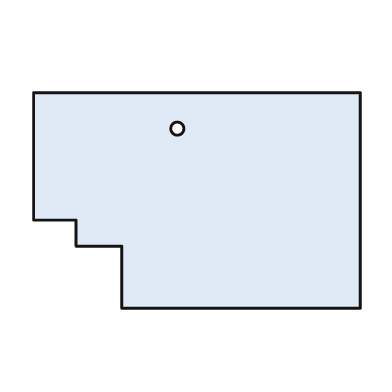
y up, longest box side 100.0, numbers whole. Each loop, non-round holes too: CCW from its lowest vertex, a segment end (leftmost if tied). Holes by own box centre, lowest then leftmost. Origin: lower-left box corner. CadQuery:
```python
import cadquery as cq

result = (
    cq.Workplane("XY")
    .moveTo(27.0, 0.0)
    .lineTo(100.0, 0.0)
    .lineTo(100.0, 66.0)
    .lineTo(0.0, 66.0)
    .lineTo(0.0, 27.0)
    .lineTo(13.0, 27.0)
    .lineTo(13.0, 19.0)
    .lineTo(27.0, 19.0)
    .close()
    .moveTo(44.0, 55.0)
    .circle(2.0)
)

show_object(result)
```